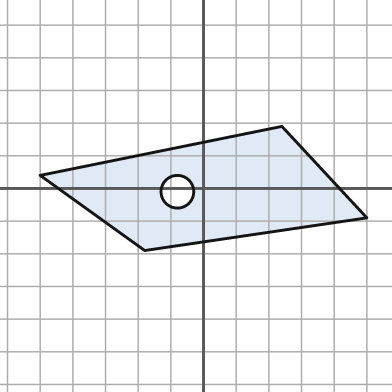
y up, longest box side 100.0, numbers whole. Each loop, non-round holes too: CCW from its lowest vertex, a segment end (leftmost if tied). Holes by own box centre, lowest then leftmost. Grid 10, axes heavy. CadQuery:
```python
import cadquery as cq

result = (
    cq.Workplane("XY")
    .moveTo(-18.0, -19.0)
    .lineTo(50.0, -9.0)
    .lineTo(24.0, 19.0)
    .lineTo(-50.0, 4.0)
    .close()
    .moveTo(-8.0, -1.0)
    .circle(5.0)
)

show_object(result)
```